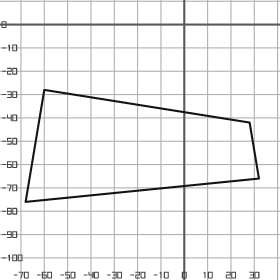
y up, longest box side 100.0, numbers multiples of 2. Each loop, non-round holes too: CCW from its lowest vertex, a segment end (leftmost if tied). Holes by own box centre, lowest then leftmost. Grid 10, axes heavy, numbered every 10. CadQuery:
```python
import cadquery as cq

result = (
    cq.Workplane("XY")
    .moveTo(-68.0, -76.0)
    .lineTo(32.0, -66.0)
    .lineTo(28.0, -42.0)
    .lineTo(-60.0, -28.0)
    .close()
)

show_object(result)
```